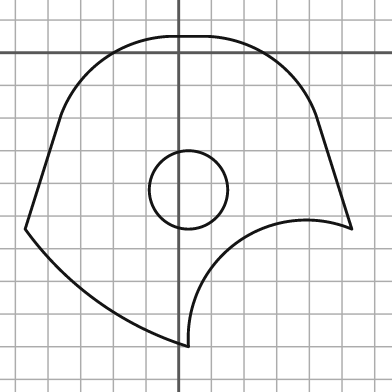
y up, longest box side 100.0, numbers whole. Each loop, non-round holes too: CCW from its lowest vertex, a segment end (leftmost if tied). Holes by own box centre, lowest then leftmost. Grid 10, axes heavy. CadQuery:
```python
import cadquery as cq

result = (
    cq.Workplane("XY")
    .moveTo(3.0, -90.0)
    .threePointArc((18.0, -58.0), (53.0, -54.0))
    .lineTo(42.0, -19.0)
    .threePointArc((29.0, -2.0), (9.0, 5.0))
    .lineTo(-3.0, 5.0)
    .threePointArc((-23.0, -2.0), (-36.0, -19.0))
    .lineTo(-47.0, -54.0)
    .threePointArc((-25.0, -76.0), (3.0, -90.0))
    .close()
    .moveTo(3.0, -42.0)
    .circle(12.0)
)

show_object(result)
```